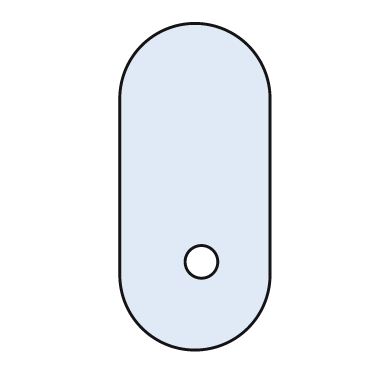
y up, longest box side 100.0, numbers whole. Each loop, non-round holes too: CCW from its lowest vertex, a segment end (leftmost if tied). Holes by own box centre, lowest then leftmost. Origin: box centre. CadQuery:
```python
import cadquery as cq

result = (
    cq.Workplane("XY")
    .moveTo(-23.0, -27.0)
    .threePointArc((0.0, -50.0), (23.0, -27.0))
    .lineTo(23.0, 27.0)
    .threePointArc((0.0, 50.0), (-23.0, 27.0))
    .close()
    .moveTo(2.0, -23.0)
    .circle(5.0)
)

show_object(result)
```